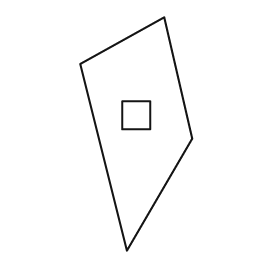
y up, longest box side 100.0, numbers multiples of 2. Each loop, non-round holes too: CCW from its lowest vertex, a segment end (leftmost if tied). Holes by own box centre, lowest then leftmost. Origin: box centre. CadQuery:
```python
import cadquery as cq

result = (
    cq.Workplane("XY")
    .moveTo(-4.0, -50.0)
    .lineTo(24.0, -2.0)
    .lineTo(12.0, 50.0)
    .lineTo(-24.0, 30.0)
    .close()
    .moveTo(-6.0, 2.0)
    .lineTo(6.0, 2.0)
    .lineTo(6.0, 14.0)
    .lineTo(-6.0, 14.0)
    .close()
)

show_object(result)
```